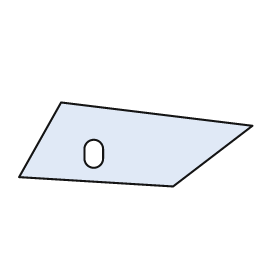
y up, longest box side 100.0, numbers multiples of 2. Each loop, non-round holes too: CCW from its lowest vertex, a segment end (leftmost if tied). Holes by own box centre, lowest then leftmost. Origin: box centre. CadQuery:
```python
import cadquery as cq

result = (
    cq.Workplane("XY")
    .moveTo(16.0, -18.0)
    .lineTo(50.0, 8.0)
    .lineTo(-32.0, 18.0)
    .lineTo(-50.0, -14.0)
    .close()
    .moveTo(-22.0, -6.0)
    .threePointArc((-18.0, -10.0), (-14.0, -6.0))
    .lineTo(-14.0, -2.0)
    .threePointArc((-18.0, 2.0), (-22.0, -2.0))
    .close()
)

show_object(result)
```